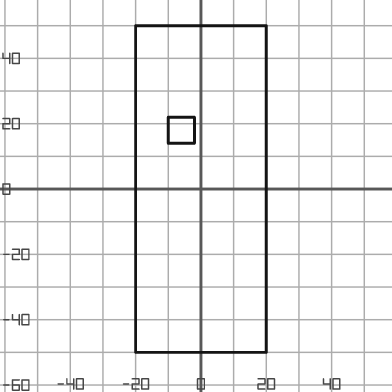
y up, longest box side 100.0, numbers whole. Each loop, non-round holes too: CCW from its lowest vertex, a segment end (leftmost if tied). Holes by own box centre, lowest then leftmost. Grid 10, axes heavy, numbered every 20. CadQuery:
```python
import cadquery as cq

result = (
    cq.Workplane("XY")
    .moveTo(-20.0, -50.0)
    .lineTo(20.0, -50.0)
    .lineTo(20.0, 50.0)
    .lineTo(-20.0, 50.0)
    .close()
    .moveTo(-10.0, 14.0)
    .lineTo(-2.0, 14.0)
    .lineTo(-2.0, 22.0)
    .lineTo(-10.0, 22.0)
    .close()
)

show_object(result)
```